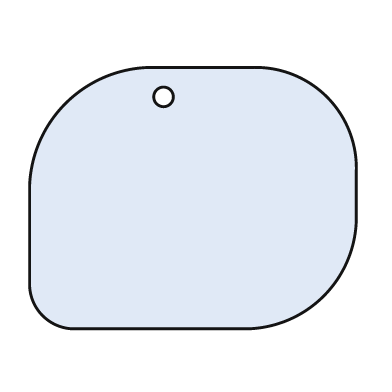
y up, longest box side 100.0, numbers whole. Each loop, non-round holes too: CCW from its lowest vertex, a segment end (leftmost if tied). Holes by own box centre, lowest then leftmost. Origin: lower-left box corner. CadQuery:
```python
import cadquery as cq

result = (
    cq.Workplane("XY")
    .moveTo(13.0, 0.0)
    .lineTo(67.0, 0.0)
    .threePointArc((90.0, 10.0), (100.0, 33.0))
    .lineTo(100.0, 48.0)
    .threePointArc((91.0, 71.0), (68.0, 80.0))
    .lineTo(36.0, 80.0)
    .threePointArc((11.0, 69.0), (0.0, 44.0))
    .lineTo(0.0, 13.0)
    .threePointArc((4.0, 4.0), (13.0, 0.0))
    .close()
    .moveTo(41.0, 71.0)
    .circle(3.0)
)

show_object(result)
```